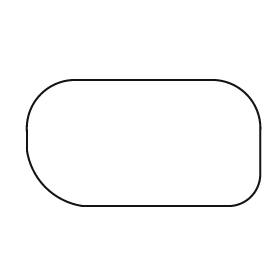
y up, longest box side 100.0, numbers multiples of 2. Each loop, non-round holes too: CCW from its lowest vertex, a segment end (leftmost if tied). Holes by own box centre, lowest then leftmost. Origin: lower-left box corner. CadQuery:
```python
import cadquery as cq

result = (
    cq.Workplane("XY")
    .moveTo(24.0, 0.0)
    .lineTo(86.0, 0.0)
    .threePointArc((96.0, 4.0), (100.0, 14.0))
    .lineTo(100.0, 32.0)
    .threePointArc((94.0, 48.0), (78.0, 54.0))
    .lineTo(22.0, 54.0)
    .threePointArc((6.0, 48.0), (0.0, 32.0))
    .lineTo(0.0, 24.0)
    .threePointArc((8.0, 8.0), (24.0, 0.0))
    .close()
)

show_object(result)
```